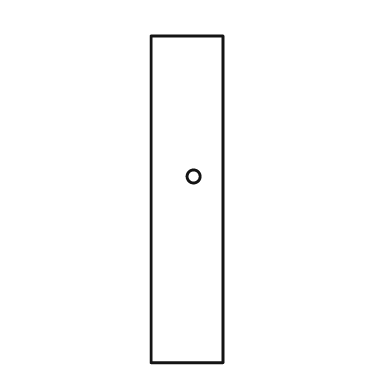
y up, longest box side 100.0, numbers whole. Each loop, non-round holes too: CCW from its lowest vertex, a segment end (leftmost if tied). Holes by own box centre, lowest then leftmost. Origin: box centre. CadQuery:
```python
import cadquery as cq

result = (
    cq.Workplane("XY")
    .moveTo(-11.0, -50.0)
    .lineTo(11.0, -50.0)
    .lineTo(11.0, 50.0)
    .lineTo(-11.0, 50.0)
    .close()
    .moveTo(2.0, 7.0)
    .circle(2.0)
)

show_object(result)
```